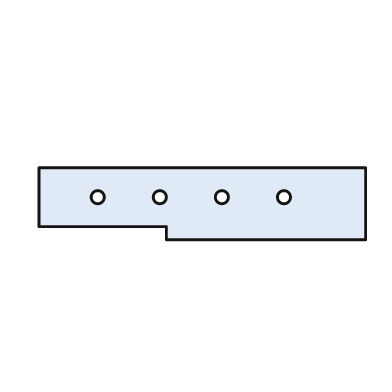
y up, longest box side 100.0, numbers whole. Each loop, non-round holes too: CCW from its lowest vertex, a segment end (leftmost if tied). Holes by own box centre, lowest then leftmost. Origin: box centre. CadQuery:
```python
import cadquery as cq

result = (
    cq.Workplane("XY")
    .moveTo(-11.0, -11.0)
    .lineTo(50.0, -11.0)
    .lineTo(50.0, 11.0)
    .lineTo(-50.0, 11.0)
    .lineTo(-50.0, -7.0)
    .lineTo(-11.0, -7.0)
    .close()
    .moveTo(-32.0, 2.0)
    .circle(2.0)
    .moveTo(-13.0, 2.0)
    .circle(2.0)
    .moveTo(6.0, 2.0)
    .circle(2.0)
    .moveTo(25.0, 2.0)
    .circle(2.0)
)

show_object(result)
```